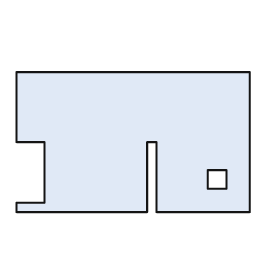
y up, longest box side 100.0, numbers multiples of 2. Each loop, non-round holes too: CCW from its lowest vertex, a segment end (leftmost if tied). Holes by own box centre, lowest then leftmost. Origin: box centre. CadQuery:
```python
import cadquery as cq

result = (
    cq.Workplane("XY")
    .moveTo(-50.0, -30.0)
    .lineTo(6.0, -30.0)
    .lineTo(6.0, 0.0)
    .lineTo(10.0, 0.0)
    .lineTo(10.0, -30.0)
    .lineTo(50.0, -30.0)
    .lineTo(50.0, 30.0)
    .lineTo(-50.0, 30.0)
    .lineTo(-50.0, 0.0)
    .lineTo(-38.0, 0.0)
    .lineTo(-38.0, -26.0)
    .lineTo(-50.0, -26.0)
    .close()
    .moveTo(32.0, -20.0)
    .lineTo(40.0, -20.0)
    .lineTo(40.0, -12.0)
    .lineTo(32.0, -12.0)
    .close()
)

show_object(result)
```